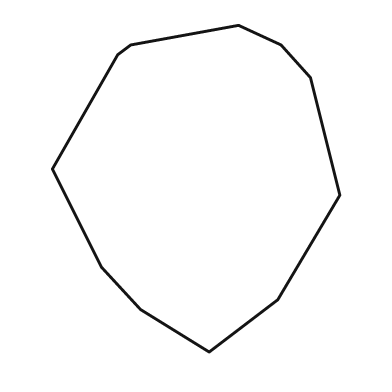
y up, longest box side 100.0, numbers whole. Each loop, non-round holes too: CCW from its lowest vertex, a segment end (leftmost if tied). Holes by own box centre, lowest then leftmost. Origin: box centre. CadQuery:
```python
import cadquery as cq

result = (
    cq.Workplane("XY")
    .moveTo(4.0, -50.0)
    .lineTo(25.0, -34.0)
    .lineTo(44.0, -2.0)
    .lineTo(35.0, 34.0)
    .lineTo(26.0, 44.0)
    .lineTo(13.0, 50.0)
    .lineTo(-20.0, 44.0)
    .lineTo(-24.0, 41.0)
    .lineTo(-44.0, 6.0)
    .lineTo(-29.0, -24.0)
    .lineTo(-17.0, -37.0)
    .close()
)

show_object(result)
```